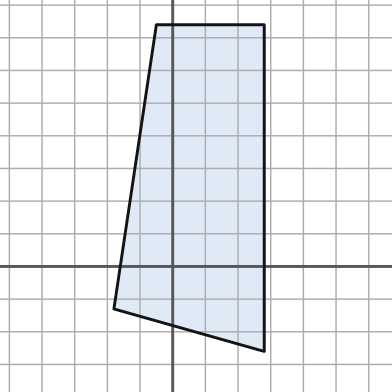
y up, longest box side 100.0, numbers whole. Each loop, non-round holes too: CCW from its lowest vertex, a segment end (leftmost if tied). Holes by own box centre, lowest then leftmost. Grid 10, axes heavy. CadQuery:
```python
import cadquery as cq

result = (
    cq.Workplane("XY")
    .moveTo(28.0, -26.0)
    .lineTo(28.0, 74.0)
    .lineTo(-5.0, 74.0)
    .lineTo(-18.0, -13.0)
    .close()
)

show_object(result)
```